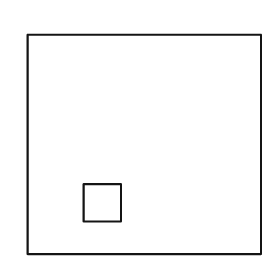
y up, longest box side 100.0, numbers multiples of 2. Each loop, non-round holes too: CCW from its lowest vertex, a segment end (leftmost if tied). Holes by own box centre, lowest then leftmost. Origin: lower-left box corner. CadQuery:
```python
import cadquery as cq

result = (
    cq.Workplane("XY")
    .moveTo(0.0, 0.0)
    .lineTo(100.0, 0.0)
    .lineTo(100.0, 94.0)
    .lineTo(0.0, 94.0)
    .close()
    .moveTo(24.0, 14.0)
    .lineTo(40.0, 14.0)
    .lineTo(40.0, 30.0)
    .lineTo(24.0, 30.0)
    .close()
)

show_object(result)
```